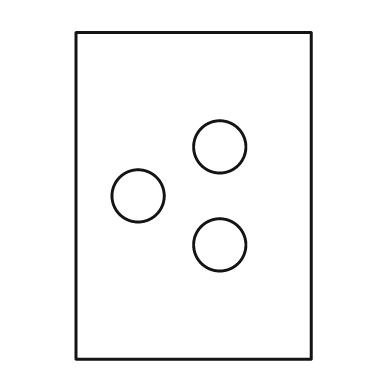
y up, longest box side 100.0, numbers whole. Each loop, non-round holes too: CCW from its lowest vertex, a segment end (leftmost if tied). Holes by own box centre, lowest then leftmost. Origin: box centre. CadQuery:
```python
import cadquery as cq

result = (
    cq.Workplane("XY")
    .moveTo(-36.0, -50.0)
    .lineTo(36.0, -50.0)
    .lineTo(36.0, 50.0)
    .lineTo(-36.0, 50.0)
    .close()
    .moveTo(8.0, -15.0)
    .circle(8.0)
    .moveTo(-17.0, 0.0)
    .circle(8.0)
    .moveTo(8.0, 15.0)
    .circle(8.0)
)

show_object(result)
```